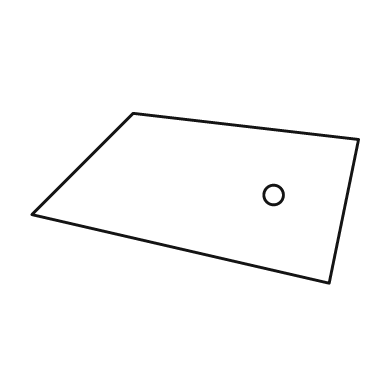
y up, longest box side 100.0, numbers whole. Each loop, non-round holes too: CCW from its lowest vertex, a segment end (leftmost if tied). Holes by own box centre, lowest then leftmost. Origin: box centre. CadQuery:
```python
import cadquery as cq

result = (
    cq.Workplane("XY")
    .moveTo(41.0, -26.0)
    .lineTo(50.0, 18.0)
    .lineTo(-19.0, 26.0)
    .lineTo(-50.0, -5.0)
    .close()
    .moveTo(24.0, 1.0)
    .circle(3.0)
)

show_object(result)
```